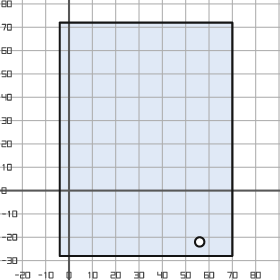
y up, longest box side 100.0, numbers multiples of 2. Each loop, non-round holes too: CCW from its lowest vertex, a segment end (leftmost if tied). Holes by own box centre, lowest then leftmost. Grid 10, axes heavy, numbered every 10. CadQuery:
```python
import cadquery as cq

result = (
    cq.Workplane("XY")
    .moveTo(-4.0, -28.0)
    .lineTo(70.0, -28.0)
    .lineTo(70.0, 72.0)
    .lineTo(-4.0, 72.0)
    .close()
    .moveTo(56.0, -22.0)
    .circle(2.0)
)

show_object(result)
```